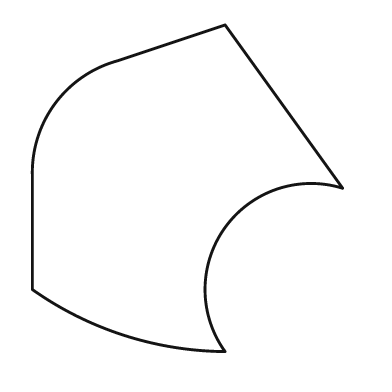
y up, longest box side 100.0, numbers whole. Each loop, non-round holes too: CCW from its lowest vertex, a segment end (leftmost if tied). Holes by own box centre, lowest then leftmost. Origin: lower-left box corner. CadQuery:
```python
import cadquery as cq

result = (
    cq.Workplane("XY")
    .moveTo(59.0, 0.0)
    .threePointArc((59.0, 38.0), (95.0, 50.0))
    .lineTo(59.0, 100.0)
    .lineTo(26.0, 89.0)
    .threePointArc((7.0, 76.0), (0.0, 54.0))
    .lineTo(0.0, 19.0)
    .threePointArc((28.0, 5.0), (59.0, 0.0))
    .close()
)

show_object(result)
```